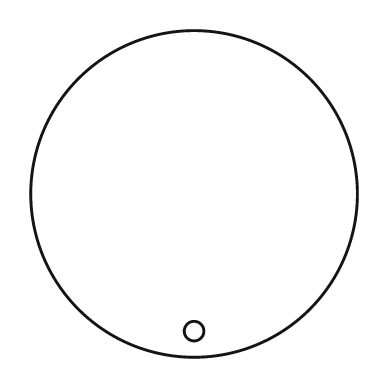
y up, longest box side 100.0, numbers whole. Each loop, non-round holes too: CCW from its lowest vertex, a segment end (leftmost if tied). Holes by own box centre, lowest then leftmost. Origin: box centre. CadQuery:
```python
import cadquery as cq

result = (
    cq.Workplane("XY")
    .moveTo(0.0, 0.0)
    .circle(50.0)
    .moveTo(0.0, -42.0)
    .circle(3.0)
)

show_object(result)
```